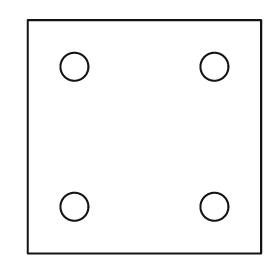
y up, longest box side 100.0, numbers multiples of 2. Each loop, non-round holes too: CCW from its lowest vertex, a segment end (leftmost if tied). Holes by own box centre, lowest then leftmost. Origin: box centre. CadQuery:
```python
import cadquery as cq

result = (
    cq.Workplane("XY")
    .moveTo(-50.0, -50.0)
    .lineTo(50.0, -50.0)
    .lineTo(50.0, 50.0)
    .lineTo(-50.0, 50.0)
    .close()
    .moveTo(-30.0, -30.0)
    .circle(6.0)
    .moveTo(30.0, -30.0)
    .circle(6.0)
    .moveTo(-30.0, 30.0)
    .circle(6.0)
    .moveTo(30.0, 30.0)
    .circle(6.0)
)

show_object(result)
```